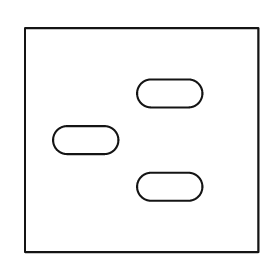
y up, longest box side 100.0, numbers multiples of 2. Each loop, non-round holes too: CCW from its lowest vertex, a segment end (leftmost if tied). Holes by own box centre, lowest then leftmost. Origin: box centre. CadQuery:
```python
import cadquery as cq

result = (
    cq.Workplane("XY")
    .moveTo(-50.0, -48.0)
    .lineTo(50.0, -48.0)
    .lineTo(50.0, 48.0)
    .lineTo(-50.0, 48.0)
    .close()
    .moveTo(4.0, -26.0)
    .lineTo(20.0, -26.0)
    .threePointArc((26.0, -20.0), (20.0, -14.0))
    .lineTo(4.0, -14.0)
    .threePointArc((-2.0, -20.0), (4.0, -26.0))
    .close()
    .moveTo(-32.0, -6.0)
    .lineTo(-16.0, -6.0)
    .threePointArc((-10.0, 0.0), (-16.0, 6.0))
    .lineTo(-32.0, 6.0)
    .threePointArc((-38.0, 0.0), (-32.0, -6.0))
    .close()
    .moveTo(4.0, 14.0)
    .lineTo(20.0, 14.0)
    .threePointArc((26.0, 20.0), (20.0, 26.0))
    .lineTo(4.0, 26.0)
    .threePointArc((-2.0, 20.0), (4.0, 14.0))
    .close()
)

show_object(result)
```